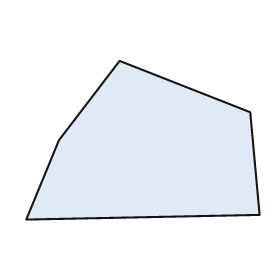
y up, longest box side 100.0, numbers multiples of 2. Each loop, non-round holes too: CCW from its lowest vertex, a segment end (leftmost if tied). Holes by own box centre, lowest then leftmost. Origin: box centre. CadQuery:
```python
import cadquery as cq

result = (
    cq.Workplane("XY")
    .moveTo(-50.0, -34.0)
    .lineTo(50.0, -32.0)
    .lineTo(46.0, 12.0)
    .lineTo(-10.0, 34.0)
    .lineTo(-36.0, 0.0)
    .close()
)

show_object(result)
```